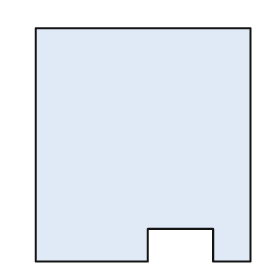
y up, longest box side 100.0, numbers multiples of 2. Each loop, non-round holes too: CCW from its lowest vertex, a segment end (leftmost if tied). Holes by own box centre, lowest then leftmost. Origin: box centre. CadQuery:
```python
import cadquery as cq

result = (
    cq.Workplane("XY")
    .moveTo(-46.0, -50.0)
    .lineTo(2.0, -50.0)
    .lineTo(2.0, -36.0)
    .lineTo(30.0, -36.0)
    .lineTo(30.0, -50.0)
    .lineTo(46.0, -50.0)
    .lineTo(46.0, 50.0)
    .lineTo(-46.0, 50.0)
    .close()
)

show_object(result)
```